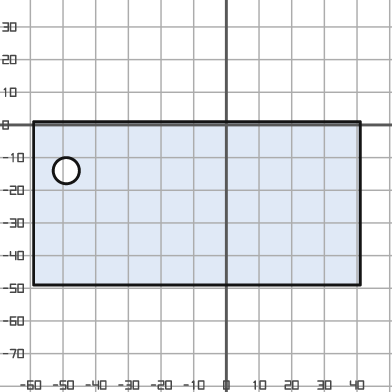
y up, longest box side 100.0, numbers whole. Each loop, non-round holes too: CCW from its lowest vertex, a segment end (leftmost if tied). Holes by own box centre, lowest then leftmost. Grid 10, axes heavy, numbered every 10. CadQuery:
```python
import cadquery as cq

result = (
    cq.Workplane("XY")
    .moveTo(-59.0, -49.0)
    .lineTo(41.0, -49.0)
    .lineTo(41.0, 1.0)
    .lineTo(-59.0, 1.0)
    .close()
    .moveTo(-49.0, -14.0)
    .circle(4.0)
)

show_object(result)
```